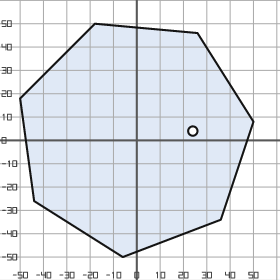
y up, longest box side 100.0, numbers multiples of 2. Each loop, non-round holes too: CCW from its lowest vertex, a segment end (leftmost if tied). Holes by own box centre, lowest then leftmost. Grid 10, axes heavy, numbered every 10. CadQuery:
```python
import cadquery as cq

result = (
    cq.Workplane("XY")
    .moveTo(-6.0, -50.0)
    .lineTo(36.0, -34.0)
    .lineTo(50.0, 8.0)
    .lineTo(26.0, 46.0)
    .lineTo(-18.0, 50.0)
    .lineTo(-50.0, 18.0)
    .lineTo(-44.0, -26.0)
    .close()
    .moveTo(24.0, 4.0)
    .circle(2.0)
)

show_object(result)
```